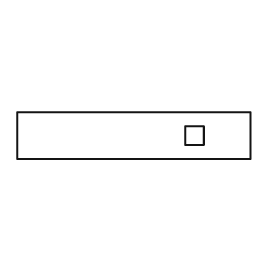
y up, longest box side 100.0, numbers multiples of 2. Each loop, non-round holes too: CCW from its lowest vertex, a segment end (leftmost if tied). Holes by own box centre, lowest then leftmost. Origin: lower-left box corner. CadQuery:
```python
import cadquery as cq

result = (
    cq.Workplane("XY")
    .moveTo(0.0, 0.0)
    .lineTo(100.0, 0.0)
    .lineTo(100.0, 20.0)
    .lineTo(0.0, 20.0)
    .close()
    .moveTo(72.0, 6.0)
    .lineTo(80.0, 6.0)
    .lineTo(80.0, 14.0)
    .lineTo(72.0, 14.0)
    .close()
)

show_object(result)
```